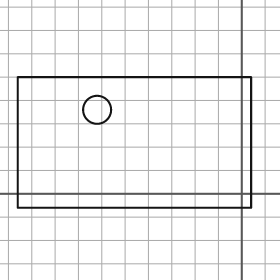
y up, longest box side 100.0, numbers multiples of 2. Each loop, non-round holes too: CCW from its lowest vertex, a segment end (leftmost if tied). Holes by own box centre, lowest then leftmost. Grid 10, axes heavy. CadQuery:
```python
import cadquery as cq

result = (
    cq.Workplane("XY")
    .moveTo(-96.0, -6.0)
    .lineTo(4.0, -6.0)
    .lineTo(4.0, 50.0)
    .lineTo(-96.0, 50.0)
    .close()
    .moveTo(-62.0, 36.0)
    .circle(6.0)
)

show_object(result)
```